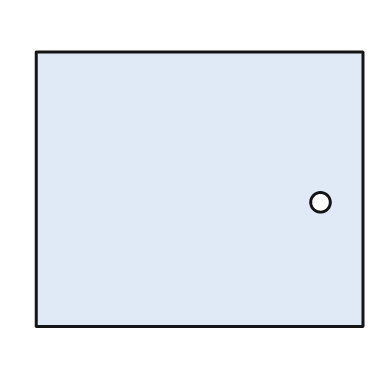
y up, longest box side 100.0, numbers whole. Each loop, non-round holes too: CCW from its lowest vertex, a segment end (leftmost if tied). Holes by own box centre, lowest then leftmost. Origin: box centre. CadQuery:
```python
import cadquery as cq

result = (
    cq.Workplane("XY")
    .moveTo(-50.0, -42.0)
    .lineTo(50.0, -42.0)
    .lineTo(50.0, 42.0)
    .lineTo(-50.0, 42.0)
    .close()
    .moveTo(37.0, -4.0)
    .circle(3.0)
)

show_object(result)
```